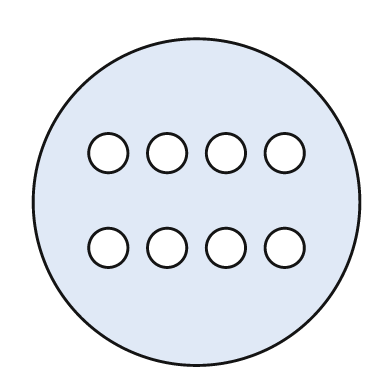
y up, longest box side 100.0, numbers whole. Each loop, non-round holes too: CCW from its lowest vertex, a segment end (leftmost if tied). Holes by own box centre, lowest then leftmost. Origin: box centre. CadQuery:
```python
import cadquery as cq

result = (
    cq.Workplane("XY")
    .moveTo(0.0, 0.0)
    .circle(50.0)
    .moveTo(-27.0, -14.0)
    .circle(6.0)
    .moveTo(-9.0, -14.0)
    .circle(6.0)
    .moveTo(9.0, -14.0)
    .circle(6.0)
    .moveTo(27.0, -14.0)
    .circle(6.0)
    .moveTo(-27.0, 15.0)
    .circle(6.0)
    .moveTo(-9.0, 15.0)
    .circle(6.0)
    .moveTo(9.0, 15.0)
    .circle(6.0)
    .moveTo(27.0, 15.0)
    .circle(6.0)
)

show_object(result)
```